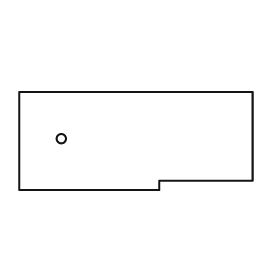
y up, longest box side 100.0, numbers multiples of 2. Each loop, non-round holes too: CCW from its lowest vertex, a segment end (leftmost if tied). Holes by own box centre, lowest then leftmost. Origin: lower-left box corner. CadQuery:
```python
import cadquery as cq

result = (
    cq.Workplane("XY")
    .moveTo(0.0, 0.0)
    .lineTo(60.0, 0.0)
    .lineTo(60.0, 4.0)
    .lineTo(100.0, 4.0)
    .lineTo(100.0, 42.0)
    .lineTo(0.0, 42.0)
    .close()
    .moveTo(18.0, 22.0)
    .circle(2.0)
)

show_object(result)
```